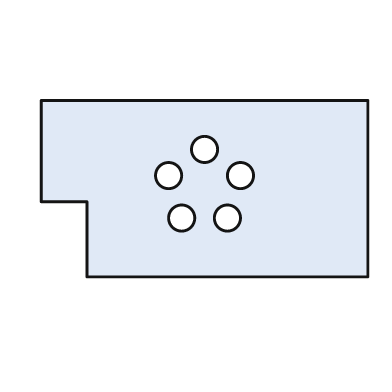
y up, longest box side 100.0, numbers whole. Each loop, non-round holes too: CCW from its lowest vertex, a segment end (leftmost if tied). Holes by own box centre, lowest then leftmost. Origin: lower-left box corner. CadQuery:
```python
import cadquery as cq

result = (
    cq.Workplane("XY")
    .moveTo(14.0, 0.0)
    .lineTo(100.0, 0.0)
    .lineTo(100.0, 54.0)
    .lineTo(0.0, 54.0)
    .lineTo(0.0, 23.0)
    .lineTo(14.0, 23.0)
    .close()
    .moveTo(43.0, 18.0)
    .circle(4.0)
    .moveTo(57.0, 18.0)
    .circle(4.0)
    .moveTo(39.0, 31.0)
    .circle(4.0)
    .moveTo(61.0, 31.0)
    .circle(4.0)
    .moveTo(50.0, 39.0)
    .circle(4.0)
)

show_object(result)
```